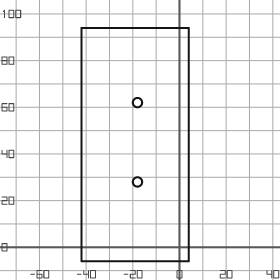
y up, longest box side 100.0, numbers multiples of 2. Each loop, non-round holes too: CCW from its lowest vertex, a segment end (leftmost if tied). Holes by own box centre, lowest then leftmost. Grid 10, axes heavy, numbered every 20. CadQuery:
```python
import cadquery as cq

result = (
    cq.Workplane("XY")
    .moveTo(-42.0, -6.0)
    .lineTo(4.0, -6.0)
    .lineTo(4.0, 94.0)
    .lineTo(-42.0, 94.0)
    .close()
    .moveTo(-18.0, 28.0)
    .circle(2.0)
    .moveTo(-18.0, 62.0)
    .circle(2.0)
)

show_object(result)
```